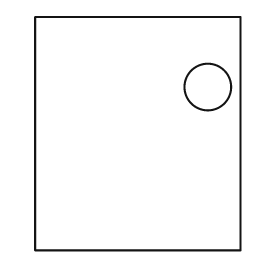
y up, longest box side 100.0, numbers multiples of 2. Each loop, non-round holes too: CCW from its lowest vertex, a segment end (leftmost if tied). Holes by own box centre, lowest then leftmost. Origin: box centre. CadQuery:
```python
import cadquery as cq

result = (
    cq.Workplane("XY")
    .moveTo(-44.0, -50.0)
    .lineTo(44.0, -50.0)
    .lineTo(44.0, 50.0)
    .lineTo(-44.0, 50.0)
    .close()
    .moveTo(30.0, 20.0)
    .circle(10.0)
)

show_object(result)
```